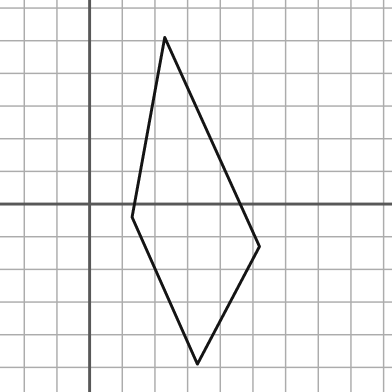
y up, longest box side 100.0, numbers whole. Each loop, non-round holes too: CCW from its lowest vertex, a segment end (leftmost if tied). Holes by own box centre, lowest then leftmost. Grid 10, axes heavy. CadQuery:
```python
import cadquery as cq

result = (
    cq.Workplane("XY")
    .moveTo(33.0, -49.0)
    .lineTo(52.0, -13.0)
    .lineTo(23.0, 51.0)
    .lineTo(13.0, -4.0)
    .close()
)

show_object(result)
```